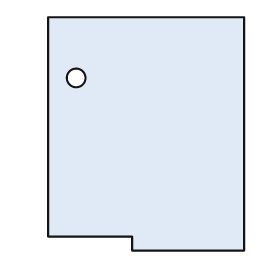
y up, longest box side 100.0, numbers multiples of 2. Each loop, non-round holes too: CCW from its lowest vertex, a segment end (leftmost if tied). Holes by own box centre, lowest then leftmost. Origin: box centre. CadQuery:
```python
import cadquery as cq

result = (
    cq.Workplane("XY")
    .moveTo(-6.0, -50.0)
    .lineTo(42.0, -50.0)
    .lineTo(42.0, 50.0)
    .lineTo(-42.0, 50.0)
    .lineTo(-42.0, -44.0)
    .lineTo(-6.0, -44.0)
    .close()
    .moveTo(-30.0, 24.0)
    .circle(4.0)
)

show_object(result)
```